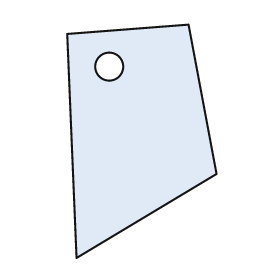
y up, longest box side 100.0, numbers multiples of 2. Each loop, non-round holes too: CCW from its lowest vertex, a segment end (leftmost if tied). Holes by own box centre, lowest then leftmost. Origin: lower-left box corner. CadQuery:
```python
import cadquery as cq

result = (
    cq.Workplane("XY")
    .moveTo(4.0, 0.0)
    .lineTo(64.0, 36.0)
    .lineTo(52.0, 100.0)
    .lineTo(0.0, 96.0)
    .close()
    .moveTo(18.0, 82.0)
    .circle(6.0)
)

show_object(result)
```